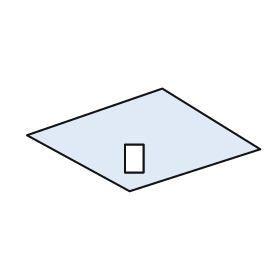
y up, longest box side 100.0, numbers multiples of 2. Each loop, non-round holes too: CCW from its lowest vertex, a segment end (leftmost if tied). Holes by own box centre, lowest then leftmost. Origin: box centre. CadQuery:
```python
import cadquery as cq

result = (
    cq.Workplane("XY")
    .moveTo(-6.0, -22.0)
    .lineTo(50.0, -4.0)
    .lineTo(8.0, 22.0)
    .lineTo(-50.0, 2.0)
    .close()
    .moveTo(-8.0, -14.0)
    .lineTo(0.0, -14.0)
    .lineTo(0.0, -2.0)
    .lineTo(-8.0, -2.0)
    .close()
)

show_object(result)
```